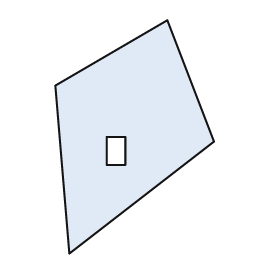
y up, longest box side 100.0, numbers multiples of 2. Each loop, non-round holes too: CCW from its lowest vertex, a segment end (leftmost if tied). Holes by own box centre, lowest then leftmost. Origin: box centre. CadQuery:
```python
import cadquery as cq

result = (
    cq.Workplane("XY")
    .moveTo(-28.0, -50.0)
    .lineTo(34.0, -2.0)
    .lineTo(14.0, 50.0)
    .lineTo(-34.0, 22.0)
    .close()
    .moveTo(-12.0, -12.0)
    .lineTo(-4.0, -12.0)
    .lineTo(-4.0, 0.0)
    .lineTo(-12.0, 0.0)
    .close()
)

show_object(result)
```